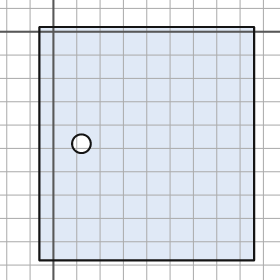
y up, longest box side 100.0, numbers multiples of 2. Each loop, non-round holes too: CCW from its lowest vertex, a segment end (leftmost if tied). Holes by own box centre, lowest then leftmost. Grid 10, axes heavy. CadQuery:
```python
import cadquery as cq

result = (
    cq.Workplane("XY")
    .moveTo(-6.0, -98.0)
    .lineTo(86.0, -98.0)
    .lineTo(86.0, 2.0)
    .lineTo(-6.0, 2.0)
    .close()
    .moveTo(12.0, -48.0)
    .circle(4.0)
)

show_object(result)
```